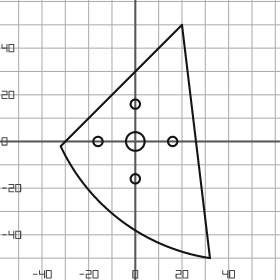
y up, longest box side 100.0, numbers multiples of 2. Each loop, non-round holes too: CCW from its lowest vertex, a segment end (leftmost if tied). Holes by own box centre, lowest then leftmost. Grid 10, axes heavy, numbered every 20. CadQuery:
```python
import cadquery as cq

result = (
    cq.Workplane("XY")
    .moveTo(32.0, -50.0)
    .lineTo(20.0, 50.0)
    .lineTo(-32.0, -2.0)
    .threePointArc((-6.0, -34.0), (32.0, -50.0))
    .close()
    .moveTo(0.0, -16.0)
    .circle(2.0)
    .moveTo(-16.0, 0.0)
    .circle(2.0)
    .moveTo(0.0, 0.0)
    .circle(4.0)
    .moveTo(16.0, 0.0)
    .circle(2.0)
    .moveTo(0.0, 16.0)
    .circle(2.0)
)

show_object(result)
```